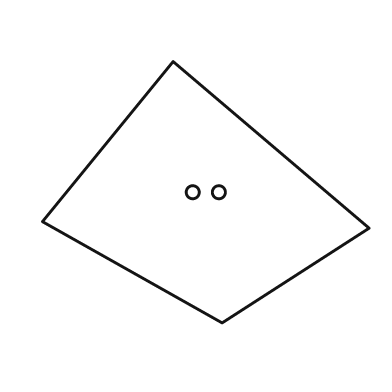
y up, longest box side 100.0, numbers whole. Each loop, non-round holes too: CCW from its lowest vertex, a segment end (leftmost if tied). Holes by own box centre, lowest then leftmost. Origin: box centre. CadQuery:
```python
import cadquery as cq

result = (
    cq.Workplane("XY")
    .moveTo(5.0, -40.0)
    .lineTo(50.0, -11.0)
    .lineTo(-10.0, 40.0)
    .lineTo(-50.0, -9.0)
    .close()
    .moveTo(-4.0, 0.0)
    .circle(2.0)
    .moveTo(4.0, 0.0)
    .circle(2.0)
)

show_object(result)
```